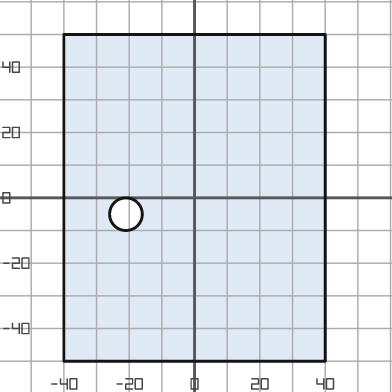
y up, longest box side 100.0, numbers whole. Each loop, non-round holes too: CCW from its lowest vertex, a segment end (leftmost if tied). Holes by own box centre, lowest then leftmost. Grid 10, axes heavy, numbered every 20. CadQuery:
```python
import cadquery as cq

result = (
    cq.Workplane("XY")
    .moveTo(-40.0, -50.0)
    .lineTo(40.0, -50.0)
    .lineTo(40.0, 50.0)
    .lineTo(-40.0, 50.0)
    .close()
    .moveTo(-21.0, -5.0)
    .circle(5.0)
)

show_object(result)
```